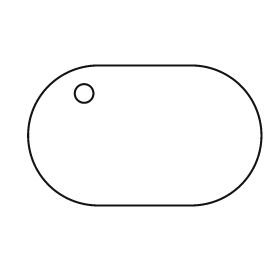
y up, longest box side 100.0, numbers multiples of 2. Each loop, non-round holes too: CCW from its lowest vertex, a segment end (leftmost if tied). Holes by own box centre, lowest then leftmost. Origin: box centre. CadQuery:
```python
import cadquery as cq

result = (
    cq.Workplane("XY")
    .moveTo(-20.0, -30.0)
    .lineTo(20.0, -30.0)
    .threePointArc((50.0, 0.0), (20.0, 30.0))
    .lineTo(-20.0, 30.0)
    .threePointArc((-50.0, 0.0), (-20.0, -30.0))
    .close()
    .moveTo(-26.0, 18.0)
    .circle(4.0)
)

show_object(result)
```